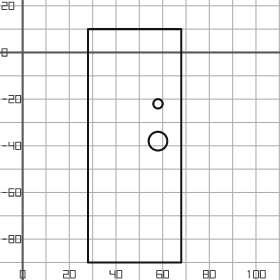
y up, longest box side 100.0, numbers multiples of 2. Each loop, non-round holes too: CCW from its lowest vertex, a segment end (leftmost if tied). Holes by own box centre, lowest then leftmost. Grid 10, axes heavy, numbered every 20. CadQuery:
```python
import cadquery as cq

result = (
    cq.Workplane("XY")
    .moveTo(28.0, -90.0)
    .lineTo(68.0, -90.0)
    .lineTo(68.0, 10.0)
    .lineTo(28.0, 10.0)
    .close()
    .moveTo(58.0, -38.0)
    .circle(4.0)
    .moveTo(58.0, -22.0)
    .circle(2.0)
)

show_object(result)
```